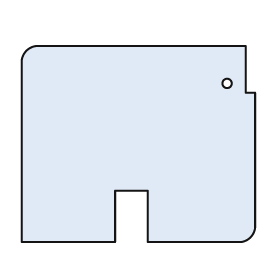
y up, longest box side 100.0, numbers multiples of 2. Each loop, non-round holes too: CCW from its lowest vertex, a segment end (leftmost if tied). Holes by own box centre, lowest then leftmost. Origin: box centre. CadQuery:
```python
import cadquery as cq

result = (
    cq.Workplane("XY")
    .moveTo(-50.0, -42.0)
    .lineTo(-10.0, -42.0)
    .lineTo(-10.0, -20.0)
    .lineTo(4.0, -20.0)
    .lineTo(4.0, -42.0)
    .lineTo(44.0, -42.0)
    .threePointArc((48.0, -40.0), (50.0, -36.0))
    .lineTo(50.0, 22.0)
    .lineTo(46.0, 22.0)
    .lineTo(46.0, 42.0)
    .lineTo(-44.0, 42.0)
    .threePointArc((-48.0, 40.0), (-50.0, 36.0))
    .close()
    .moveTo(38.0, 26.0)
    .circle(2.0)
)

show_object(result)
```